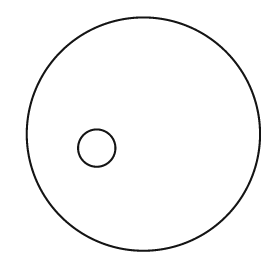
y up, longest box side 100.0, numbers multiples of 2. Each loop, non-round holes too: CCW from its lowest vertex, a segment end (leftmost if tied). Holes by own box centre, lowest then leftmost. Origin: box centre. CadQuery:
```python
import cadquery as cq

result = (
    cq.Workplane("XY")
    .moveTo(0.0, 0.0)
    .circle(50.0)
    .moveTo(-20.0, -6.0)
    .circle(8.0)
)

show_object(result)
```